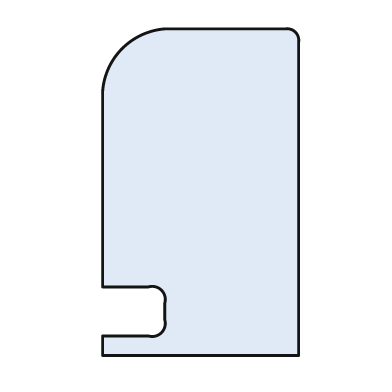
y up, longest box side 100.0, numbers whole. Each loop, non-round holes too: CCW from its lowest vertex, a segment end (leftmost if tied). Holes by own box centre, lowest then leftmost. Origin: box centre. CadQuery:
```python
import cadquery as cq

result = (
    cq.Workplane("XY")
    .moveTo(-30.0, -50.0)
    .lineTo(30.0, -50.0)
    .lineTo(30.0, 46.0)
    .threePointArc((29.0, 49.0), (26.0, 50.0))
    .lineTo(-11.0, 50.0)
    .threePointArc((-24.0, 44.0), (-30.0, 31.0))
    .lineTo(-30.0, -29.0)
    .lineTo(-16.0, -29.0)
    .threePointArc((-12.0, -30.0), (-11.0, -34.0))
    .lineTo(-11.0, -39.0)
    .threePointArc((-12.0, -43.0), (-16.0, -44.0))
    .lineTo(-30.0, -44.0)
    .close()
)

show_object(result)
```